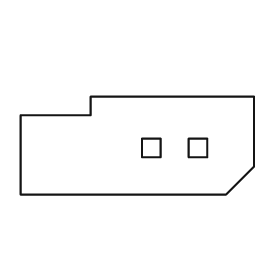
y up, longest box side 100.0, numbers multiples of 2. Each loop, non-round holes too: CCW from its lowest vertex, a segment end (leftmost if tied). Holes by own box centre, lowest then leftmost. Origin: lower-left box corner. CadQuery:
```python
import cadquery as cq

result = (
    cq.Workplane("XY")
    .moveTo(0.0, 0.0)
    .lineTo(88.0, 0.0)
    .lineTo(100.0, 12.0)
    .lineTo(100.0, 42.0)
    .lineTo(30.0, 42.0)
    .lineTo(30.0, 34.0)
    .lineTo(0.0, 34.0)
    .close()
    .moveTo(52.0, 16.0)
    .lineTo(60.0, 16.0)
    .lineTo(60.0, 24.0)
    .lineTo(52.0, 24.0)
    .close()
    .moveTo(72.0, 16.0)
    .lineTo(80.0, 16.0)
    .lineTo(80.0, 24.0)
    .lineTo(72.0, 24.0)
    .close()
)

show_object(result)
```